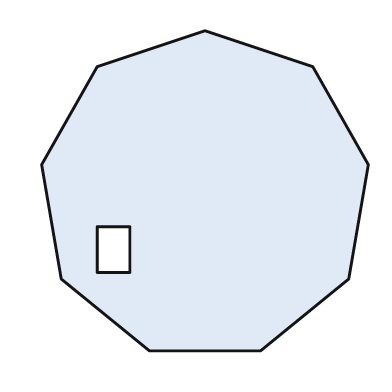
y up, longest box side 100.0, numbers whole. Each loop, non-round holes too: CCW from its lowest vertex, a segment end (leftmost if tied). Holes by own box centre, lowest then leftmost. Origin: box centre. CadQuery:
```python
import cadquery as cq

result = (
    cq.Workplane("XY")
    .moveTo(-17.0, -49.0)
    .lineTo(17.0, -49.0)
    .lineTo(44.0, -27.0)
    .lineTo(50.0, 8.0)
    .lineTo(33.0, 38.0)
    .lineTo(0.0, 49.0)
    .lineTo(-33.0, 38.0)
    .lineTo(-50.0, 8.0)
    .lineTo(-44.0, -27.0)
    .close()
    .moveTo(-33.0, -25.0)
    .lineTo(-23.0, -25.0)
    .lineTo(-23.0, -11.0)
    .lineTo(-33.0, -11.0)
    .close()
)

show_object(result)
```